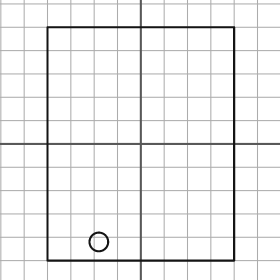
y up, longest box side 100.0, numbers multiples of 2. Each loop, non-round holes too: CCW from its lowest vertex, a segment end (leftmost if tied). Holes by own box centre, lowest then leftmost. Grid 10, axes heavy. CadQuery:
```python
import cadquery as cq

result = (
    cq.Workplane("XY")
    .moveTo(-40.0, -50.0)
    .lineTo(40.0, -50.0)
    .lineTo(40.0, 50.0)
    .lineTo(-40.0, 50.0)
    .close()
    .moveTo(-18.0, -42.0)
    .circle(4.0)
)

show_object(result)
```